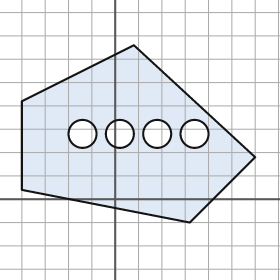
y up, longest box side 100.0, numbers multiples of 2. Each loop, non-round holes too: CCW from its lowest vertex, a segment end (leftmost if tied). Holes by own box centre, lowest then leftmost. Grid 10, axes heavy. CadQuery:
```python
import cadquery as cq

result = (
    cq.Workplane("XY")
    .moveTo(32.0, -10.0)
    .lineTo(60.0, 18.0)
    .lineTo(8.0, 66.0)
    .lineTo(-40.0, 42.0)
    .lineTo(-40.0, 4.0)
    .close()
    .moveTo(-14.0, 28.0)
    .circle(6.0)
    .moveTo(2.0, 28.0)
    .circle(6.0)
    .moveTo(18.0, 28.0)
    .circle(6.0)
    .moveTo(34.0, 28.0)
    .circle(6.0)
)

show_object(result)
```